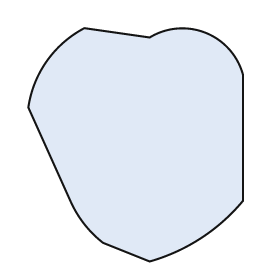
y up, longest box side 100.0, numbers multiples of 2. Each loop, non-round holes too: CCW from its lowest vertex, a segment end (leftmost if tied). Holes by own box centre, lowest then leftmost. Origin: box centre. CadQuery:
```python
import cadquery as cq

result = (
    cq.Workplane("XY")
    .moveTo(6.0, -50.0)
    .threePointArc((28.0, -40.0), (46.0, -24.0))
    .lineTo(46.0, 30.0)
    .threePointArc((30.0, 48.0), (6.0, 46.0))
    .lineTo(-22.0, 50.0)
    .threePointArc((-38.0, 36.0), (-46.0, 16.0))
    .lineTo(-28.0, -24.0)
    .threePointArc((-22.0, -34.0), (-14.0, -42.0))
    .close()
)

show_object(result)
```